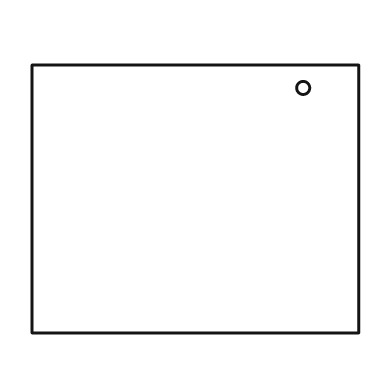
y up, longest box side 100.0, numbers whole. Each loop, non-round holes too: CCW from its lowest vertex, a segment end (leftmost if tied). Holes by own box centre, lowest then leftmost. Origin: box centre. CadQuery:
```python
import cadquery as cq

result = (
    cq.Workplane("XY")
    .moveTo(-50.0, -41.0)
    .lineTo(50.0, -41.0)
    .lineTo(50.0, 41.0)
    .lineTo(-50.0, 41.0)
    .close()
    .moveTo(33.0, 34.0)
    .circle(2.0)
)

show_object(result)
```